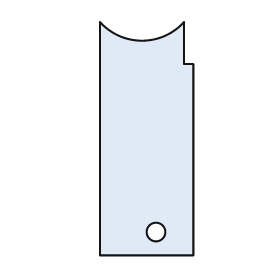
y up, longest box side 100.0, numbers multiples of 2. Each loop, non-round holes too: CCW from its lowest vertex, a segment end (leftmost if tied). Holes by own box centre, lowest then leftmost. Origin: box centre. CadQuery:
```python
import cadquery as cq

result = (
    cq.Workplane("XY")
    .moveTo(-20.0, -50.0)
    .lineTo(20.0, -50.0)
    .lineTo(20.0, 32.0)
    .lineTo(16.0, 32.0)
    .lineTo(16.0, 50.0)
    .threePointArc((-2.0, 42.0), (-20.0, 50.0))
    .close()
    .moveTo(4.0, -40.0)
    .circle(4.0)
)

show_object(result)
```